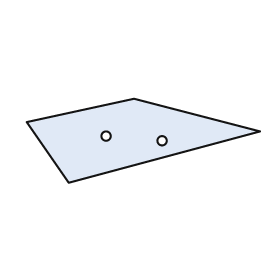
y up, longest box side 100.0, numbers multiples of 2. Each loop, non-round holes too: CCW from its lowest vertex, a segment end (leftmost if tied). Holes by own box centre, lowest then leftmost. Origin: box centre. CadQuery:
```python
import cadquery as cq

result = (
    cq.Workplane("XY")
    .moveTo(-32.0, -18.0)
    .lineTo(50.0, 4.0)
    .lineTo(-4.0, 18.0)
    .lineTo(-50.0, 8.0)
    .close()
    .moveTo(8.0, 0.0)
    .circle(2.0)
    .moveTo(-16.0, 2.0)
    .circle(2.0)
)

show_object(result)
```